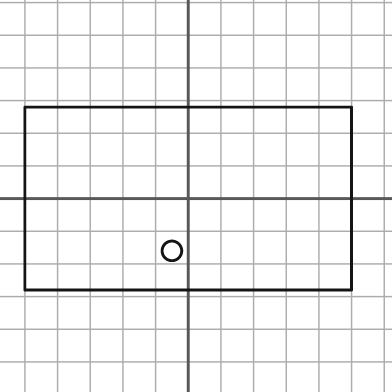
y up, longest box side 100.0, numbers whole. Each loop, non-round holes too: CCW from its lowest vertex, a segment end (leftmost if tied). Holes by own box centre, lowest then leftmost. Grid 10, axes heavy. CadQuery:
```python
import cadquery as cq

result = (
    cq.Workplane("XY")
    .moveTo(-50.0, -28.0)
    .lineTo(50.0, -28.0)
    .lineTo(50.0, 28.0)
    .lineTo(-50.0, 28.0)
    .close()
    .moveTo(-5.0, -16.0)
    .circle(3.0)
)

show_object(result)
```